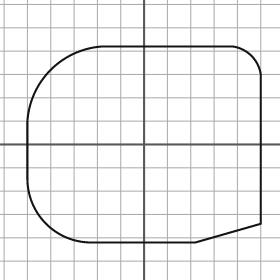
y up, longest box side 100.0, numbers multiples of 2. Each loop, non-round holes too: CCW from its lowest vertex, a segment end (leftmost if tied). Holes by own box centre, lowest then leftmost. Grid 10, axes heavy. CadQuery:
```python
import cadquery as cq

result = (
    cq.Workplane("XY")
    .moveTo(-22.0, -42.0)
    .lineTo(22.0, -42.0)
    .lineTo(50.0, -34.0)
    .lineTo(50.0, 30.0)
    .threePointArc((46.0, 38.0), (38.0, 42.0))
    .lineTo(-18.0, 42.0)
    .threePointArc((-40.0, 32.0), (-50.0, 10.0))
    .lineTo(-50.0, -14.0)
    .threePointArc((-42.0, -34.0), (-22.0, -42.0))
    .close()
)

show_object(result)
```